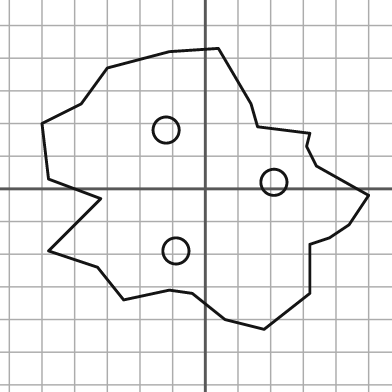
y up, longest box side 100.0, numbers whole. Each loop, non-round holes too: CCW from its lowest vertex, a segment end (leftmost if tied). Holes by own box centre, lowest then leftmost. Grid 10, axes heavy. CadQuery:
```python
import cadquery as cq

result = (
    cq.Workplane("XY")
    .moveTo(18.0, -43.0)
    .lineTo(32.0, -32.0)
    .lineTo(32.0, -17.0)
    .lineTo(38.0, -15.0)
    .lineTo(44.0, -11.0)
    .lineTo(50.0, -2.0)
    .lineTo(34.0, 7.0)
    .lineTo(31.0, 13.0)
    .lineTo(32.0, 17.0)
    .lineTo(16.0, 19.0)
    .lineTo(14.0, 26.0)
    .lineTo(4.0, 43.0)
    .lineTo(-11.0, 42.0)
    .lineTo(-30.0, 37.0)
    .lineTo(-38.0, 26.0)
    .lineTo(-50.0, 20.0)
    .lineTo(-48.0, 3.0)
    .lineTo(-32.0, -3.0)
    .lineTo(-48.0, -19.0)
    .lineTo(-33.0, -24.0)
    .lineTo(-25.0, -34.0)
    .lineTo(-11.0, -31.0)
    .lineTo(-4.0, -32.0)
    .lineTo(6.0, -40.0)
    .close()
    .moveTo(-9.0, -19.0)
    .circle(4.0)
    .moveTo(21.0, 2.0)
    .circle(4.0)
    .moveTo(-12.0, 18.0)
    .circle(4.0)
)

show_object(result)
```